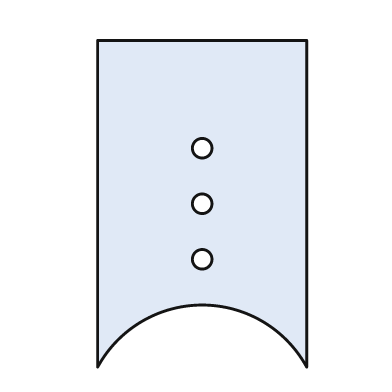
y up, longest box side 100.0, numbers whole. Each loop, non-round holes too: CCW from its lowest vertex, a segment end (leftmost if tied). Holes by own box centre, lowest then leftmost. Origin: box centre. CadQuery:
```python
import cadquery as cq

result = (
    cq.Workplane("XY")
    .moveTo(-32.0, -50.0)
    .threePointArc((0.0, -31.0), (32.0, -50.0))
    .lineTo(32.0, 50.0)
    .lineTo(-32.0, 50.0)
    .close()
    .moveTo(0.0, -17.0)
    .circle(3.0)
    .moveTo(0.0, 0.0)
    .circle(3.0)
    .moveTo(0.0, 17.0)
    .circle(3.0)
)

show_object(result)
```